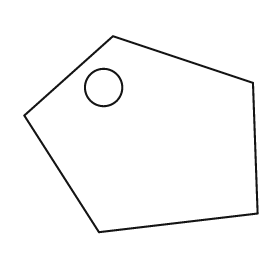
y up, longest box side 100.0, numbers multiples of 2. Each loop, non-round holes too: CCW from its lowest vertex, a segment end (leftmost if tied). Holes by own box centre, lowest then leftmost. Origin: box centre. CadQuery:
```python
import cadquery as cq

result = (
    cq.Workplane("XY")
    .moveTo(-18.0, -42.0)
    .lineTo(50.0, -34.0)
    .lineTo(48.0, 22.0)
    .lineTo(-12.0, 42.0)
    .lineTo(-50.0, 8.0)
    .close()
    .moveTo(-16.0, 20.0)
    .circle(8.0)
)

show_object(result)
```